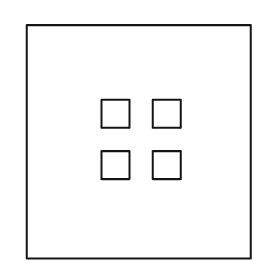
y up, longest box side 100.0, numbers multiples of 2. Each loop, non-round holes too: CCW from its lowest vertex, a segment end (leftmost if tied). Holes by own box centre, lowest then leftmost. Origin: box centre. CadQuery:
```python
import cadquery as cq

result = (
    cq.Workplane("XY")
    .moveTo(-48.0, -50.0)
    .lineTo(48.0, -50.0)
    .lineTo(48.0, 50.0)
    .lineTo(-48.0, 50.0)
    .close()
    .moveTo(-16.0, -16.0)
    .lineTo(-4.0, -16.0)
    .lineTo(-4.0, -4.0)
    .lineTo(-16.0, -4.0)
    .close()
    .moveTo(6.0, -16.0)
    .lineTo(18.0, -16.0)
    .lineTo(18.0, -4.0)
    .lineTo(6.0, -4.0)
    .close()
    .moveTo(-16.0, 6.0)
    .lineTo(-4.0, 6.0)
    .lineTo(-4.0, 18.0)
    .lineTo(-16.0, 18.0)
    .close()
    .moveTo(6.0, 6.0)
    .lineTo(18.0, 6.0)
    .lineTo(18.0, 18.0)
    .lineTo(6.0, 18.0)
    .close()
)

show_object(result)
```